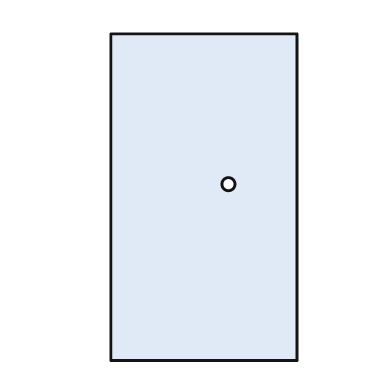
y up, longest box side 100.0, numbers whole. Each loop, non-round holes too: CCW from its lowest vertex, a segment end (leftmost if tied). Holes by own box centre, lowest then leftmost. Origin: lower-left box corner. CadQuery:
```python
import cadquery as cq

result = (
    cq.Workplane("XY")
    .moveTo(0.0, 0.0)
    .lineTo(57.0, 0.0)
    .lineTo(57.0, 100.0)
    .lineTo(0.0, 100.0)
    .close()
    .moveTo(36.0, 54.0)
    .circle(2.0)
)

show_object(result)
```